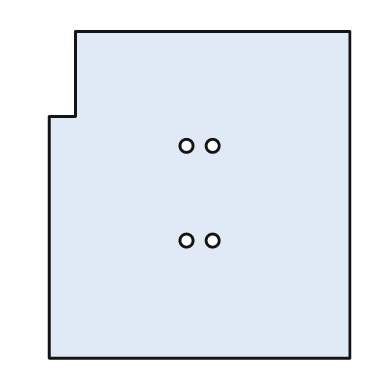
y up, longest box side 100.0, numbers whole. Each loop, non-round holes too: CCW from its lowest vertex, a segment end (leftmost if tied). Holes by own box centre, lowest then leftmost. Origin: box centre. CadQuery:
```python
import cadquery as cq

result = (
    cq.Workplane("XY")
    .moveTo(-46.0, -50.0)
    .lineTo(46.0, -50.0)
    .lineTo(46.0, 50.0)
    .lineTo(-38.0, 50.0)
    .lineTo(-38.0, 24.0)
    .lineTo(-46.0, 24.0)
    .close()
    .moveTo(-4.0, -14.0)
    .circle(2.0)
    .moveTo(4.0, -14.0)
    .circle(2.0)
    .moveTo(-4.0, 15.0)
    .circle(2.0)
    .moveTo(4.0, 15.0)
    .circle(2.0)
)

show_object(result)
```